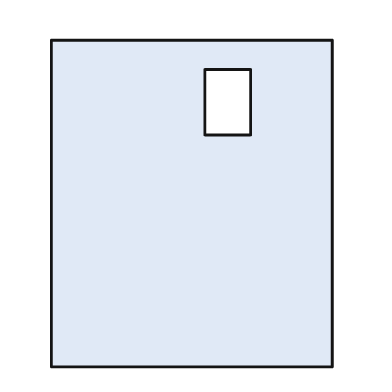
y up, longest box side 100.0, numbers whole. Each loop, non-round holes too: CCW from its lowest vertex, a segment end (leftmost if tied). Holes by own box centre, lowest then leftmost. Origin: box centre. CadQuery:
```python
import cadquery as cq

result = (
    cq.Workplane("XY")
    .moveTo(-43.0, -50.0)
    .lineTo(43.0, -50.0)
    .lineTo(43.0, 50.0)
    .lineTo(-43.0, 50.0)
    .close()
    .moveTo(4.0, 21.0)
    .lineTo(18.0, 21.0)
    .lineTo(18.0, 41.0)
    .lineTo(4.0, 41.0)
    .close()
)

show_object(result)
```